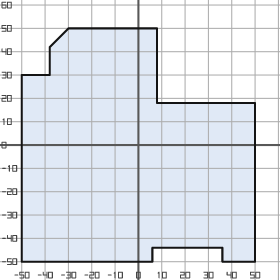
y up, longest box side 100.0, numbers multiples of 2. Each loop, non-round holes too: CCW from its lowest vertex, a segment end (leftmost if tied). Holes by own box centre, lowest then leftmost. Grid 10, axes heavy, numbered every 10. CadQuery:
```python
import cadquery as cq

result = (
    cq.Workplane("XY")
    .moveTo(-50.0, -50.0)
    .lineTo(6.0, -50.0)
    .lineTo(6.0, -44.0)
    .lineTo(36.0, -44.0)
    .lineTo(36.0, -50.0)
    .lineTo(50.0, -50.0)
    .lineTo(50.0, 18.0)
    .lineTo(8.0, 18.0)
    .lineTo(8.0, 50.0)
    .lineTo(-30.0, 50.0)
    .lineTo(-38.0, 42.0)
    .lineTo(-38.0, 30.0)
    .lineTo(-50.0, 30.0)
    .close()
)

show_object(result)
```